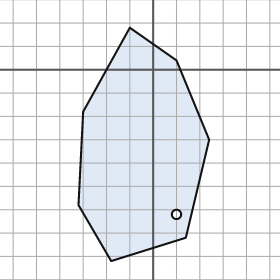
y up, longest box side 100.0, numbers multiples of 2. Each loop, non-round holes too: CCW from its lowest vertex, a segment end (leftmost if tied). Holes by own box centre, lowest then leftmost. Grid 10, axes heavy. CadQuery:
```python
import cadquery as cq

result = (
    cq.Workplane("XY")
    .moveTo(-18.0, -82.0)
    .lineTo(14.0, -72.0)
    .lineTo(24.0, -30.0)
    .lineTo(10.0, 4.0)
    .lineTo(-10.0, 18.0)
    .lineTo(-30.0, -18.0)
    .lineTo(-32.0, -58.0)
    .close()
    .moveTo(10.0, -62.0)
    .circle(2.0)
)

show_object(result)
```